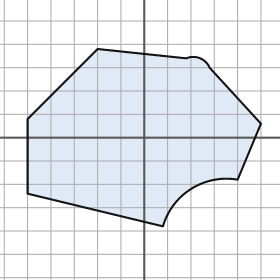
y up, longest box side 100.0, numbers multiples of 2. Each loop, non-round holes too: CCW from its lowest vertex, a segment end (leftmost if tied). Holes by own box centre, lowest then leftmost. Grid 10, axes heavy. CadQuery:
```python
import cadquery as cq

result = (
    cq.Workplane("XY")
    .moveTo(8.0, -38.0)
    .threePointArc((20.0, -22.0), (40.0, -18.0))
    .lineTo(50.0, 6.0)
    .lineTo(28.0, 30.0)
    .threePointArc((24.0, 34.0), (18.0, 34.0))
    .lineTo(-20.0, 38.0)
    .lineTo(-50.0, 8.0)
    .lineTo(-50.0, -24.0)
    .close()
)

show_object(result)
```